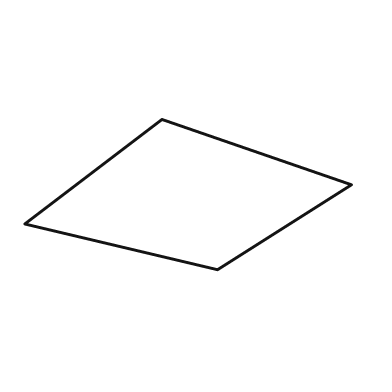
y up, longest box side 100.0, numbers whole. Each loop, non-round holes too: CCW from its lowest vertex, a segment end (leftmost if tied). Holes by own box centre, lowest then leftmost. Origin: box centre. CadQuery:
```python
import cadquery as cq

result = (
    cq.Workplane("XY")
    .moveTo(9.0, -23.0)
    .lineTo(50.0, 3.0)
    .lineTo(-8.0, 23.0)
    .lineTo(-50.0, -9.0)
    .close()
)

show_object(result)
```